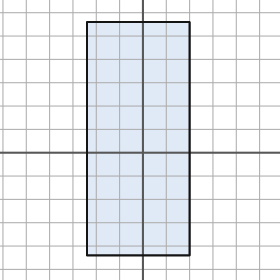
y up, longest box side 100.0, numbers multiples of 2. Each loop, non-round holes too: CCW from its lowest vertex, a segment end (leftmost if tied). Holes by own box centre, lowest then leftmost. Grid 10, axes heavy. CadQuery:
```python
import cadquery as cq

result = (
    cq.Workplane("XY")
    .moveTo(-24.0, -44.0)
    .lineTo(20.0, -44.0)
    .lineTo(20.0, 56.0)
    .lineTo(-24.0, 56.0)
    .close()
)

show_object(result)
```